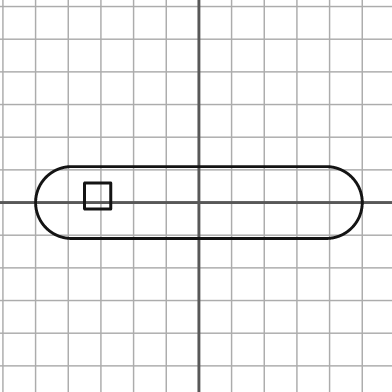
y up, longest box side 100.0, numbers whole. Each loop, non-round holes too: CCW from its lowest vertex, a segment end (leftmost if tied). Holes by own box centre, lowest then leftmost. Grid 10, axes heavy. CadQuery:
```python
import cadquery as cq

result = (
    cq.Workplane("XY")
    .moveTo(-39.0, -11.0)
    .lineTo(39.0, -11.0)
    .threePointArc((50.0, 0.0), (39.0, 11.0))
    .lineTo(-39.0, 11.0)
    .threePointArc((-50.0, 0.0), (-39.0, -11.0))
    .close()
    .moveTo(-35.0, -2.0)
    .lineTo(-27.0, -2.0)
    .lineTo(-27.0, 6.0)
    .lineTo(-35.0, 6.0)
    .close()
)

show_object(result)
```